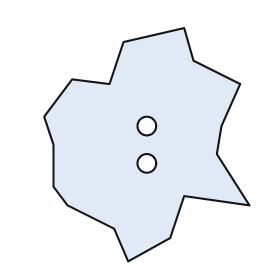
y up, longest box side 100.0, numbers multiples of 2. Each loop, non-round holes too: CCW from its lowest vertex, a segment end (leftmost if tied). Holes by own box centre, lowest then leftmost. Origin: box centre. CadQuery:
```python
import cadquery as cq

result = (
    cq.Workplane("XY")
    .moveTo(-8.0, -50.0)
    .lineTo(10.0, -40.0)
    .lineTo(16.0, -22.0)
    .lineTo(44.0, -26.0)
    .lineTo(30.0, -4.0)
    .lineTo(32.0, 8.0)
    .lineTo(40.0, 26.0)
    .lineTo(20.0, 36.0)
    .lineTo(16.0, 50.0)
    .lineTo(-10.0, 44.0)
    .lineTo(-16.0, 26.0)
    .lineTo(-32.0, 28.0)
    .lineTo(-44.0, 12.0)
    .lineTo(-40.0, 0.0)
    .lineTo(-40.0, -18.0)
    .lineTo(-34.0, -26.0)
    .lineTo(-14.0, -36.0)
    .close()
    .moveTo(0.0, -8.0)
    .circle(4.0)
    .moveTo(0.0, 8.0)
    .circle(4.0)
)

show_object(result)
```